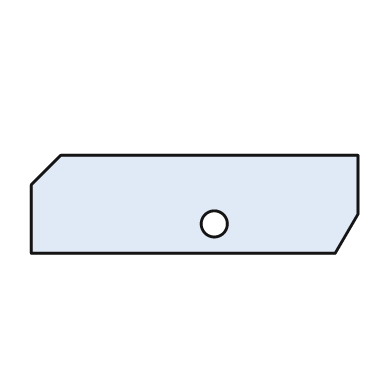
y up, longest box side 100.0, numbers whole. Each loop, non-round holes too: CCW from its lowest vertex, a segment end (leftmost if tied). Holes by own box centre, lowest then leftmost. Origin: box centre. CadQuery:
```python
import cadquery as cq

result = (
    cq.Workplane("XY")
    .moveTo(-50.0, -15.0)
    .lineTo(43.0, -15.0)
    .lineTo(50.0, -3.0)
    .lineTo(50.0, 15.0)
    .lineTo(-41.0, 15.0)
    .lineTo(-50.0, 6.0)
    .close()
    .moveTo(6.0, -6.0)
    .circle(4.0)
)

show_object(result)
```